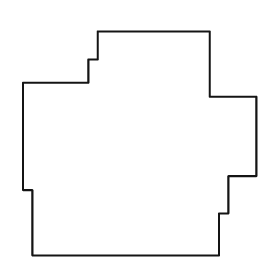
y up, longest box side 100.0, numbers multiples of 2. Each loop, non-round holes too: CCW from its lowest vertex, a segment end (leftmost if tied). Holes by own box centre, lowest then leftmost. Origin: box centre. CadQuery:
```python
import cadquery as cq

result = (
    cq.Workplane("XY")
    .moveTo(-46.0, -48.0)
    .lineTo(34.0, -48.0)
    .lineTo(34.0, -30.0)
    .lineTo(38.0, -30.0)
    .lineTo(38.0, -14.0)
    .lineTo(50.0, -14.0)
    .lineTo(50.0, 20.0)
    .lineTo(30.0, 20.0)
    .lineTo(30.0, 48.0)
    .lineTo(-18.0, 48.0)
    .lineTo(-18.0, 36.0)
    .lineTo(-22.0, 36.0)
    .lineTo(-22.0, 26.0)
    .lineTo(-50.0, 26.0)
    .lineTo(-50.0, -20.0)
    .lineTo(-46.0, -20.0)
    .close()
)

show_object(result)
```